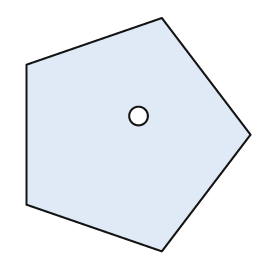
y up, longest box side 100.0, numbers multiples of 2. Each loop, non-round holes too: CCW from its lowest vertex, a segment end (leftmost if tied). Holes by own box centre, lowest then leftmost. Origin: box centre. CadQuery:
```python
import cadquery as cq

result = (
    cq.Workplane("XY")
    .moveTo(10.0, -50.0)
    .lineTo(48.0, 0.0)
    .lineTo(10.0, 50.0)
    .lineTo(-48.0, 30.0)
    .lineTo(-48.0, -30.0)
    .close()
    .moveTo(0.0, 8.0)
    .circle(4.0)
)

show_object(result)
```